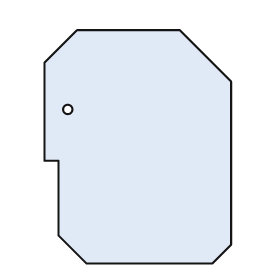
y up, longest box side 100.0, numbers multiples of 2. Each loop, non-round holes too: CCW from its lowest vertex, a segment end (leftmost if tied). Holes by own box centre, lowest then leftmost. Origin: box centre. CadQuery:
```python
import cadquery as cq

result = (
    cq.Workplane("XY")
    .moveTo(-22.0, -50.0)
    .lineTo(32.0, -50.0)
    .lineTo(40.0, -42.0)
    .lineTo(40.0, 28.0)
    .lineTo(18.0, 50.0)
    .lineTo(-26.0, 50.0)
    .lineTo(-40.0, 36.0)
    .lineTo(-40.0, -6.0)
    .lineTo(-34.0, -6.0)
    .lineTo(-34.0, -38.0)
    .close()
    .moveTo(-30.0, 16.0)
    .circle(2.0)
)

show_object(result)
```